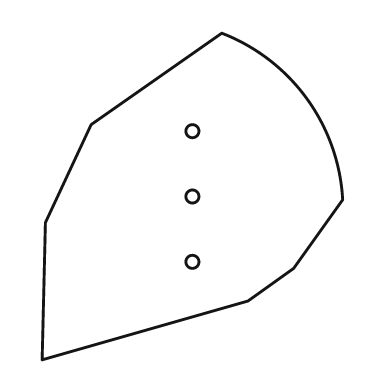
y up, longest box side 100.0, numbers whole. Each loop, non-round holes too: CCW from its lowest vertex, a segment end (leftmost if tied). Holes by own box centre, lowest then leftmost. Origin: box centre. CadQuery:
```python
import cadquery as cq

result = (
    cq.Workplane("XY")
    .moveTo(-46.0, -50.0)
    .lineTo(17.0, -32.0)
    .lineTo(31.0, -22.0)
    .lineTo(46.0, -1.0)
    .threePointArc((35.0, 30.0), (9.0, 50.0))
    .lineTo(-31.0, 22.0)
    .lineTo(-45.0, -8.0)
    .close()
    .moveTo(0.0, -20.0)
    .circle(2.0)
    .moveTo(0.0, 0.0)
    .circle(2.0)
    .moveTo(0.0, 20.0)
    .circle(2.0)
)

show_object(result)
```